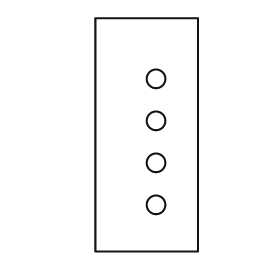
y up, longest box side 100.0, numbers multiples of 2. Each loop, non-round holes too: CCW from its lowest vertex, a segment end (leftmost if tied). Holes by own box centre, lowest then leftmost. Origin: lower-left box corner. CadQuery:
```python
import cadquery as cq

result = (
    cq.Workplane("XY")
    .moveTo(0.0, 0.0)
    .lineTo(44.0, 0.0)
    .lineTo(44.0, 100.0)
    .lineTo(0.0, 100.0)
    .close()
    .moveTo(26.0, 20.0)
    .circle(4.0)
    .moveTo(26.0, 38.0)
    .circle(4.0)
    .moveTo(26.0, 56.0)
    .circle(4.0)
    .moveTo(26.0, 74.0)
    .circle(4.0)
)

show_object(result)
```